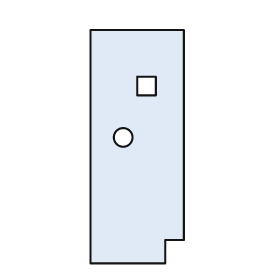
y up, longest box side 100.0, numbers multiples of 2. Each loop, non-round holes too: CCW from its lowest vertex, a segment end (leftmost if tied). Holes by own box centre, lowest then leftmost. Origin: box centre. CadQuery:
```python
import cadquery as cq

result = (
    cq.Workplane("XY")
    .moveTo(-20.0, -50.0)
    .lineTo(12.0, -50.0)
    .lineTo(12.0, -40.0)
    .lineTo(20.0, -40.0)
    .lineTo(20.0, 50.0)
    .lineTo(-20.0, 50.0)
    .close()
    .moveTo(-6.0, 4.0)
    .circle(4.0)
    .moveTo(0.0, 22.0)
    .lineTo(8.0, 22.0)
    .lineTo(8.0, 30.0)
    .lineTo(0.0, 30.0)
    .close()
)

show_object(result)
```